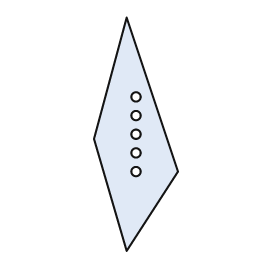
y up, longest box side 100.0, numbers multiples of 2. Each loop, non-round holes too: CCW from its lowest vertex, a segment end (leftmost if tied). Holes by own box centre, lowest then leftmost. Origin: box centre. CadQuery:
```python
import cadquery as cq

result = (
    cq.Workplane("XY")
    .moveTo(-4.0, -50.0)
    .lineTo(18.0, -16.0)
    .lineTo(-4.0, 50.0)
    .lineTo(-18.0, -2.0)
    .close()
    .moveTo(0.0, -16.0)
    .circle(2.0)
    .moveTo(0.0, -8.0)
    .circle(2.0)
    .moveTo(0.0, 0.0)
    .circle(2.0)
    .moveTo(0.0, 8.0)
    .circle(2.0)
    .moveTo(0.0, 16.0)
    .circle(2.0)
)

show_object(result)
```